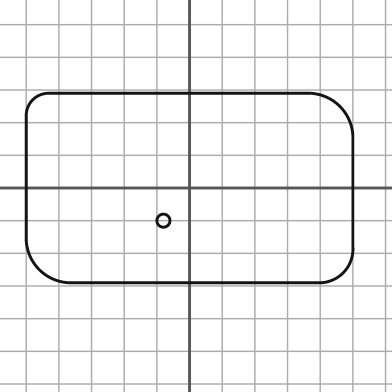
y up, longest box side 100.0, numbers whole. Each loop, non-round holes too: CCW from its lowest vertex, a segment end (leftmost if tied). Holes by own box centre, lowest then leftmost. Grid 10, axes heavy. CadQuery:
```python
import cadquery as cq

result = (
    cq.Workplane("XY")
    .moveTo(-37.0, -29.0)
    .lineTo(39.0, -29.0)
    .threePointArc((47.0, -26.0), (50.0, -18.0))
    .lineTo(50.0, 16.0)
    .threePointArc((46.0, 25.0), (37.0, 29.0))
    .lineTo(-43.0, 29.0)
    .threePointArc((-48.0, 27.0), (-50.0, 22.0))
    .lineTo(-50.0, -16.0)
    .threePointArc((-46.0, -25.0), (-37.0, -29.0))
    .close()
    .moveTo(-8.0, -10.0)
    .circle(2.0)
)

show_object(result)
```